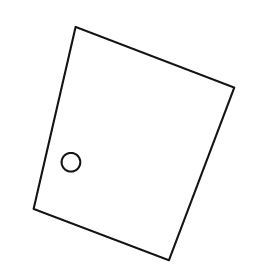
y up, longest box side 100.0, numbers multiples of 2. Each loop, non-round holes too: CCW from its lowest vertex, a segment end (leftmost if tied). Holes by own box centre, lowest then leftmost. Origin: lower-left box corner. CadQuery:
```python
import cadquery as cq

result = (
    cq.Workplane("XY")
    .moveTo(58.0, 0.0)
    .lineTo(86.0, 74.0)
    .lineTo(18.0, 100.0)
    .lineTo(0.0, 22.0)
    .close()
    .moveTo(16.0, 42.0)
    .circle(4.0)
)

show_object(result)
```